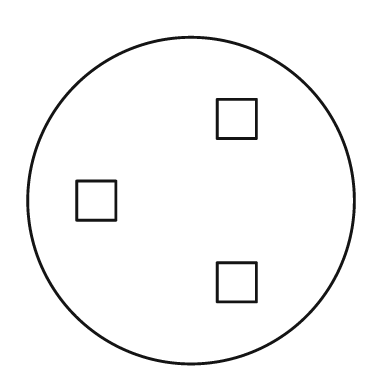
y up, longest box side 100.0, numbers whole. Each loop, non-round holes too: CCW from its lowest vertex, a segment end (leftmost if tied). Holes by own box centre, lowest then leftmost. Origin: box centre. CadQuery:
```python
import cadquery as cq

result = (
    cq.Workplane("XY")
    .moveTo(0.0, 0.0)
    .circle(50.0)
    .moveTo(8.0, -31.0)
    .lineTo(20.0, -31.0)
    .lineTo(20.0, -19.0)
    .lineTo(8.0, -19.0)
    .close()
    .moveTo(-35.0, -6.0)
    .lineTo(-23.0, -6.0)
    .lineTo(-23.0, 6.0)
    .lineTo(-35.0, 6.0)
    .close()
    .moveTo(8.0, 19.0)
    .lineTo(20.0, 19.0)
    .lineTo(20.0, 31.0)
    .lineTo(8.0, 31.0)
    .close()
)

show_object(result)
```